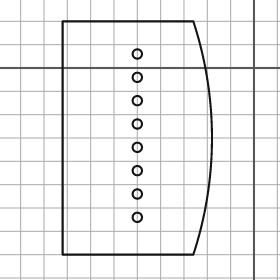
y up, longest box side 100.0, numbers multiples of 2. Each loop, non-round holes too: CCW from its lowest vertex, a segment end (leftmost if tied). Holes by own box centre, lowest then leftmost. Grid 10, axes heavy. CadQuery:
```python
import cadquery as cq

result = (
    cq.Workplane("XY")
    .moveTo(-82.0, -80.0)
    .lineTo(-26.0, -80.0)
    .threePointArc((-18.0, -30.0), (-26.0, 20.0))
    .lineTo(-82.0, 20.0)
    .close()
    .moveTo(-50.0, -64.0)
    .circle(2.0)
    .moveTo(-50.0, -54.0)
    .circle(2.0)
    .moveTo(-50.0, -44.0)
    .circle(2.0)
    .moveTo(-50.0, -34.0)
    .circle(2.0)
    .moveTo(-50.0, -24.0)
    .circle(2.0)
    .moveTo(-50.0, -14.0)
    .circle(2.0)
    .moveTo(-50.0, -4.0)
    .circle(2.0)
    .moveTo(-50.0, 6.0)
    .circle(2.0)
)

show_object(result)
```